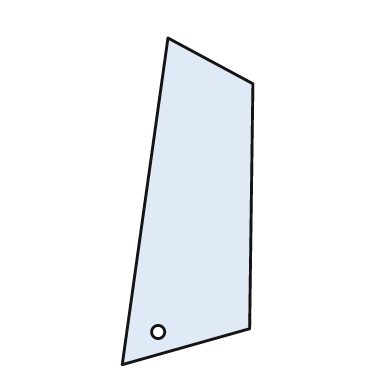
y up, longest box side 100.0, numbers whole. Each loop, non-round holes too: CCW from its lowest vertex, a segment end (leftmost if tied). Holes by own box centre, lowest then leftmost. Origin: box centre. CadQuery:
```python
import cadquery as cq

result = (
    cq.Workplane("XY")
    .moveTo(-20.0, -50.0)
    .lineTo(19.0, -39.0)
    .lineTo(20.0, 36.0)
    .lineTo(-6.0, 50.0)
    .close()
    .moveTo(-9.0, -40.0)
    .circle(2.0)
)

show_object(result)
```